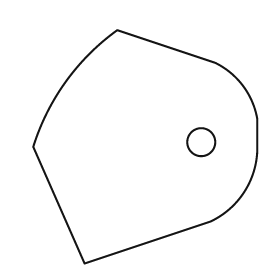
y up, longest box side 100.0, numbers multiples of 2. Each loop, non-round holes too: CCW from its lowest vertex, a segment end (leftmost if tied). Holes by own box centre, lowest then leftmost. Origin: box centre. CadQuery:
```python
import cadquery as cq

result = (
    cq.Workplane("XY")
    .moveTo(-26.0, -50.0)
    .lineTo(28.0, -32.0)
    .threePointArc((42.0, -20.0), (48.0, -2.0))
    .lineTo(48.0, 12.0)
    .threePointArc((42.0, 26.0), (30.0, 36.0))
    .lineTo(-12.0, 50.0)
    .threePointArc((-34.0, 28.0), (-48.0, 0.0))
    .close()
    .moveTo(24.0, 2.0)
    .circle(6.0)
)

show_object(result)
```